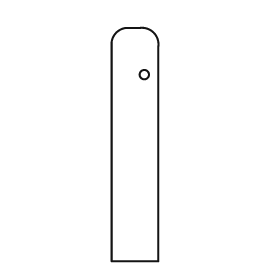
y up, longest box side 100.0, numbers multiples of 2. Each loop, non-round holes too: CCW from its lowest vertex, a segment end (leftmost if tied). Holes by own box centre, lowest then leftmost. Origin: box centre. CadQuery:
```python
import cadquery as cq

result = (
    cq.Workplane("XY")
    .moveTo(-10.0, -50.0)
    .lineTo(10.0, -50.0)
    .lineTo(10.0, 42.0)
    .threePointArc((8.0, 48.0), (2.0, 50.0))
    .lineTo(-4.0, 50.0)
    .threePointArc((-8.0, 48.0), (-10.0, 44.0))
    .close()
    .moveTo(4.0, 30.0)
    .circle(2.0)
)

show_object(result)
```